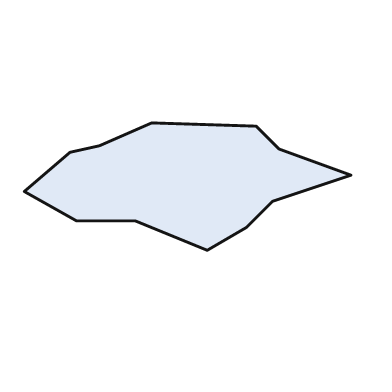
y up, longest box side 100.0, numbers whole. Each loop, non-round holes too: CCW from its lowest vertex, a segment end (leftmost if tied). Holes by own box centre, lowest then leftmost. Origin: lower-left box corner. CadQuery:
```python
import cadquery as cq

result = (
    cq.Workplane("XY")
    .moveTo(56.0, 0.0)
    .lineTo(68.0, 7.0)
    .lineTo(76.0, 15.0)
    .lineTo(100.0, 23.0)
    .lineTo(78.0, 31.0)
    .lineTo(71.0, 38.0)
    .lineTo(39.0, 39.0)
    .lineTo(23.0, 32.0)
    .lineTo(14.0, 30.0)
    .lineTo(0.0, 18.0)
    .lineTo(16.0, 9.0)
    .lineTo(34.0, 9.0)
    .close()
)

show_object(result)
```